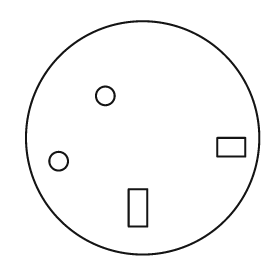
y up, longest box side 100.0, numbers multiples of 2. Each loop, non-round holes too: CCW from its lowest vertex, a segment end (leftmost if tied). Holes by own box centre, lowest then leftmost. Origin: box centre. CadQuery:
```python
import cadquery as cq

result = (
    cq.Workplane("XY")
    .moveTo(0.0, 0.0)
    .circle(50.0)
    .moveTo(-6.0, -38.0)
    .lineTo(2.0, -38.0)
    .lineTo(2.0, -22.0)
    .lineTo(-6.0, -22.0)
    .close()
    .moveTo(-36.0, -10.0)
    .circle(4.0)
    .moveTo(32.0, -8.0)
    .lineTo(44.0, -8.0)
    .lineTo(44.0, 0.0)
    .lineTo(32.0, 0.0)
    .close()
    .moveTo(-16.0, 18.0)
    .circle(4.0)
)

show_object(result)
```